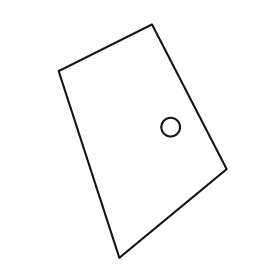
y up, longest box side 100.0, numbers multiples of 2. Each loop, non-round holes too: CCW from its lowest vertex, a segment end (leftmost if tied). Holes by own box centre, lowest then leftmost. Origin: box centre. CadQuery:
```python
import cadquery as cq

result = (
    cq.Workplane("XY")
    .moveTo(-10.0, -50.0)
    .lineTo(36.0, -12.0)
    .lineTo(4.0, 50.0)
    .lineTo(-36.0, 30.0)
    .close()
    .moveTo(12.0, 6.0)
    .circle(4.0)
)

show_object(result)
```